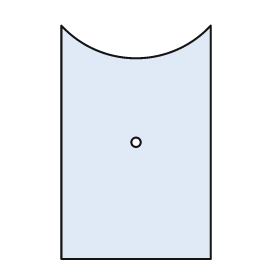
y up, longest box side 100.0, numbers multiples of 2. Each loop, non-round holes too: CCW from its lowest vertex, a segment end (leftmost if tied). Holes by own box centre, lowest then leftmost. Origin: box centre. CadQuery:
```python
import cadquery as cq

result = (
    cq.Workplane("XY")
    .moveTo(-32.0, -50.0)
    .lineTo(32.0, -50.0)
    .lineTo(32.0, 50.0)
    .threePointArc((0.0, 36.0), (-32.0, 50.0))
    .close()
    .moveTo(0.0, 0.0)
    .circle(2.0)
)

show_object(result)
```